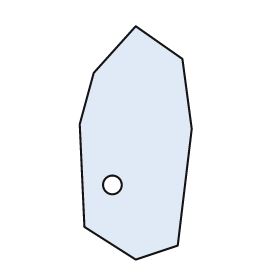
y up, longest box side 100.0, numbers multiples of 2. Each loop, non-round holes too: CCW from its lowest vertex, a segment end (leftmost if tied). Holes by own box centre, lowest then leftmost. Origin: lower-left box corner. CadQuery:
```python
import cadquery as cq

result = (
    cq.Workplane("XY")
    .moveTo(24.0, 0.0)
    .lineTo(42.0, 6.0)
    .lineTo(48.0, 56.0)
    .lineTo(44.0, 86.0)
    .lineTo(24.0, 100.0)
    .lineTo(6.0, 80.0)
    .lineTo(0.0, 58.0)
    .lineTo(2.0, 14.0)
    .close()
    .moveTo(14.0, 32.0)
    .circle(4.0)
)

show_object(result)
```